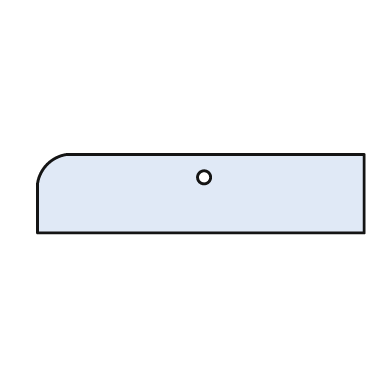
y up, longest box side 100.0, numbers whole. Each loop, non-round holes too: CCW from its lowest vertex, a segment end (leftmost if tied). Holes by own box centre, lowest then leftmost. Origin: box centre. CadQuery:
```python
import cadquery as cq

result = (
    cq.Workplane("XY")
    .moveTo(-50.0, -12.0)
    .lineTo(50.0, -12.0)
    .lineTo(50.0, 12.0)
    .lineTo(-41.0, 12.0)
    .threePointArc((-47.0, 9.0), (-50.0, 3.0))
    .close()
    .moveTo(1.0, 5.0)
    .circle(2.0)
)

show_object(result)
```